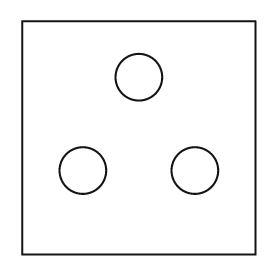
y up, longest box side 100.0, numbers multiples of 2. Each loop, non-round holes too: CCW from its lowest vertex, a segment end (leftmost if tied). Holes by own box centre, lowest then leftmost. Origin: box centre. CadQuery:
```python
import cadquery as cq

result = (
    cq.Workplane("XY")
    .moveTo(-50.0, -50.0)
    .lineTo(50.0, -50.0)
    .lineTo(50.0, 50.0)
    .lineTo(-50.0, 50.0)
    .close()
    .moveTo(-24.0, -14.0)
    .circle(10.0)
    .moveTo(24.0, -14.0)
    .circle(10.0)
    .moveTo(0.0, 26.0)
    .circle(10.0)
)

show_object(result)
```